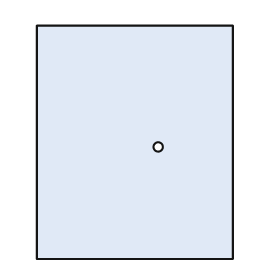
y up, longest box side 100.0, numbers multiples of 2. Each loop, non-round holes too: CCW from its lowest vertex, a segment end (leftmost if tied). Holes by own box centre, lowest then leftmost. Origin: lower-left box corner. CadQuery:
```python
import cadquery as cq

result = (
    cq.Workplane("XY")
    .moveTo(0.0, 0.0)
    .lineTo(84.0, 0.0)
    .lineTo(84.0, 100.0)
    .lineTo(0.0, 100.0)
    .close()
    .moveTo(52.0, 48.0)
    .circle(2.0)
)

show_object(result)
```